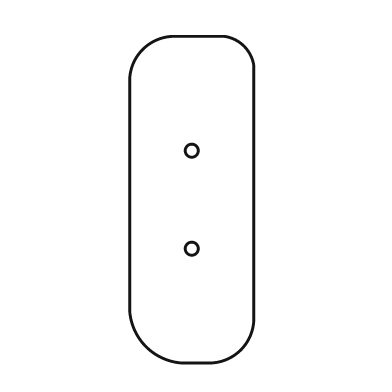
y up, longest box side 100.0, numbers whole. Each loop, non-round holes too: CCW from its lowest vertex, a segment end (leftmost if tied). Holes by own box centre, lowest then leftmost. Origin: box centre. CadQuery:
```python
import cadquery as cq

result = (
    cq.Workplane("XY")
    .moveTo(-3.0, -50.0)
    .lineTo(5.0, -50.0)
    .threePointArc((15.0, -46.0), (19.0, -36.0))
    .lineTo(19.0, 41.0)
    .threePointArc((16.0, 47.0), (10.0, 50.0))
    .lineTo(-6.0, 50.0)
    .threePointArc((-15.0, 46.0), (-19.0, 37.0))
    .lineTo(-19.0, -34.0)
    .threePointArc((-14.0, -45.0), (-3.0, -50.0))
    .close()
    .moveTo(0.0, -15.0)
    .circle(2.0)
    .moveTo(0.0, 15.0)
    .circle(2.0)
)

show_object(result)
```